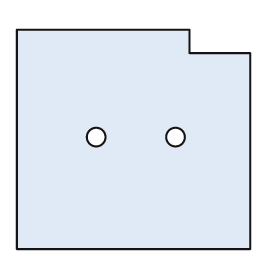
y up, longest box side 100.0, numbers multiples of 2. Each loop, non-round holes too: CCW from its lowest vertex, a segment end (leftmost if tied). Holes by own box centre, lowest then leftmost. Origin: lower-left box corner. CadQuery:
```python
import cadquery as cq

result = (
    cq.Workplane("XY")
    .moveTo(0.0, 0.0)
    .lineTo(100.0, 0.0)
    .lineTo(100.0, 84.0)
    .lineTo(74.0, 84.0)
    .lineTo(74.0, 94.0)
    .lineTo(0.0, 94.0)
    .close()
    .moveTo(34.0, 48.0)
    .circle(4.0)
    .moveTo(68.0, 48.0)
    .circle(4.0)
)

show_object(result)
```